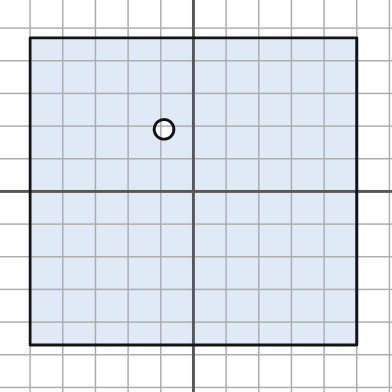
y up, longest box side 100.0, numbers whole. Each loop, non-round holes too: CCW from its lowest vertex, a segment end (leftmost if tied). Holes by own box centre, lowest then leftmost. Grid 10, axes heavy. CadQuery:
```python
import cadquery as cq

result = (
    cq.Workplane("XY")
    .moveTo(-50.0, -47.0)
    .lineTo(50.0, -47.0)
    .lineTo(50.0, 47.0)
    .lineTo(-50.0, 47.0)
    .close()
    .moveTo(-9.0, 19.0)
    .circle(3.0)
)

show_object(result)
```